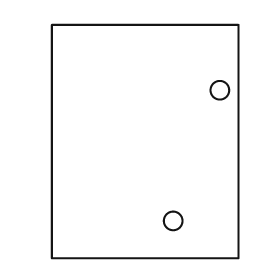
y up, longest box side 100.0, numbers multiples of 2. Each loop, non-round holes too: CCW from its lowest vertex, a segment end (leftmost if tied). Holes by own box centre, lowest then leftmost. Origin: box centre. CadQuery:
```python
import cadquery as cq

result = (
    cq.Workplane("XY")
    .moveTo(-40.0, -50.0)
    .lineTo(40.0, -50.0)
    .lineTo(40.0, 50.0)
    .lineTo(-40.0, 50.0)
    .close()
    .moveTo(12.0, -34.0)
    .circle(4.0)
    .moveTo(32.0, 22.0)
    .circle(4.0)
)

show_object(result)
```